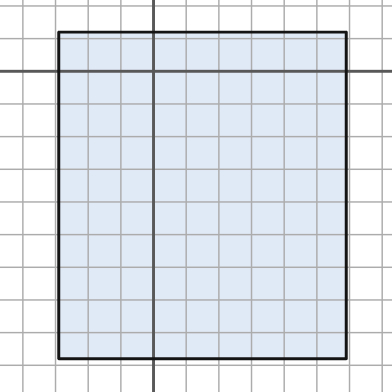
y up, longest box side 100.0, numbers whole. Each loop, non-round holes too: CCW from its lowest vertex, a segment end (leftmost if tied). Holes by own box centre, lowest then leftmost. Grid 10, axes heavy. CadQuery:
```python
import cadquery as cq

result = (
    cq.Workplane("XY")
    .moveTo(-29.0, -88.0)
    .lineTo(59.0, -88.0)
    .lineTo(59.0, 12.0)
    .lineTo(-29.0, 12.0)
    .close()
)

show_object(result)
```